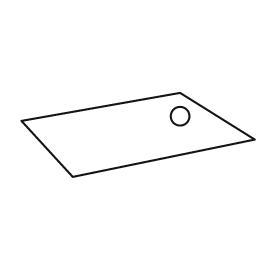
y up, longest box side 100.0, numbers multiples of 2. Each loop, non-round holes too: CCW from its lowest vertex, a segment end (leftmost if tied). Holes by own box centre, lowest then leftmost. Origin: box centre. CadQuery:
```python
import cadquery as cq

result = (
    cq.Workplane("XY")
    .moveTo(-28.0, -18.0)
    .lineTo(50.0, -2.0)
    .lineTo(18.0, 18.0)
    .lineTo(-50.0, 6.0)
    .close()
    .moveTo(18.0, 8.0)
    .circle(4.0)
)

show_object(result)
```